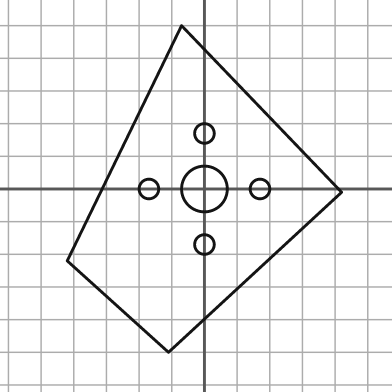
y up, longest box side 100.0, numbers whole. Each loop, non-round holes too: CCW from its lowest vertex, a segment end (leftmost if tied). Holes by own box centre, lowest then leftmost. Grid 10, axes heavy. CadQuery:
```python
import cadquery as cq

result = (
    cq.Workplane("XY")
    .moveTo(-11.0, -50.0)
    .lineTo(42.0, -1.0)
    .lineTo(-7.0, 50.0)
    .lineTo(-42.0, -22.0)
    .close()
    .moveTo(0.0, -17.0)
    .circle(3.0)
    .moveTo(-17.0, 0.0)
    .circle(3.0)
    .moveTo(0.0, 0.0)
    .circle(7.0)
    .moveTo(17.0, 0.0)
    .circle(3.0)
    .moveTo(0.0, 17.0)
    .circle(3.0)
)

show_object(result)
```